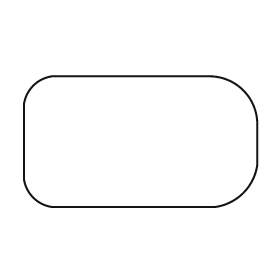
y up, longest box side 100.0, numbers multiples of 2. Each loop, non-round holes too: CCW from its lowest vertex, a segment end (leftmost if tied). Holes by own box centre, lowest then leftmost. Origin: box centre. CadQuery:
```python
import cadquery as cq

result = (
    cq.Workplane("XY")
    .moveTo(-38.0, -28.0)
    .lineTo(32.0, -28.0)
    .threePointArc((44.0, -22.0), (50.0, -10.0))
    .lineTo(50.0, 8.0)
    .threePointArc((44.0, 22.0), (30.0, 28.0))
    .lineTo(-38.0, 28.0)
    .threePointArc((-46.0, 24.0), (-50.0, 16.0))
    .lineTo(-50.0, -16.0)
    .threePointArc((-46.0, -24.0), (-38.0, -28.0))
    .close()
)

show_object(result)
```